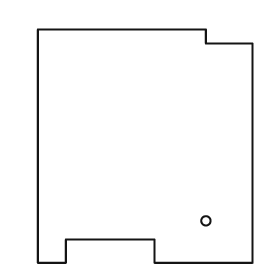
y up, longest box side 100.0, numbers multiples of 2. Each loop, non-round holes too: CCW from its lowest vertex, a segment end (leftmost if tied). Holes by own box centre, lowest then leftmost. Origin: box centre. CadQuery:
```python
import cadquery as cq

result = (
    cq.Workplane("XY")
    .moveTo(-46.0, -50.0)
    .lineTo(-34.0, -50.0)
    .lineTo(-34.0, -40.0)
    .lineTo(4.0, -40.0)
    .lineTo(4.0, -50.0)
    .lineTo(46.0, -50.0)
    .lineTo(46.0, 44.0)
    .lineTo(26.0, 44.0)
    .lineTo(26.0, 50.0)
    .lineTo(-46.0, 50.0)
    .close()
    .moveTo(26.0, -32.0)
    .circle(2.0)
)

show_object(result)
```